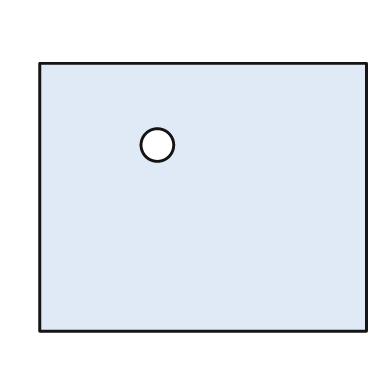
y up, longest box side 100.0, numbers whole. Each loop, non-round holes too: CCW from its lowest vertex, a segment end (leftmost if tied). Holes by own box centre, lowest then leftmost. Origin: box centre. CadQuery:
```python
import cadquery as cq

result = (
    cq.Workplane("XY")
    .moveTo(-50.0, -41.0)
    .lineTo(50.0, -41.0)
    .lineTo(50.0, 41.0)
    .lineTo(-50.0, 41.0)
    .close()
    .moveTo(-14.0, 16.0)
    .circle(5.0)
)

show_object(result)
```